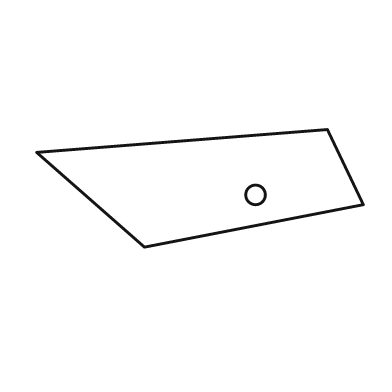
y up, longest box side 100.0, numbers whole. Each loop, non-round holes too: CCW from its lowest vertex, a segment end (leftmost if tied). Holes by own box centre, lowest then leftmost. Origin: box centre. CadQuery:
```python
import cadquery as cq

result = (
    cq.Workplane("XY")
    .moveTo(-17.0, -18.0)
    .lineTo(50.0, -5.0)
    .lineTo(39.0, 18.0)
    .lineTo(-50.0, 11.0)
    .close()
    .moveTo(17.0, -2.0)
    .circle(3.0)
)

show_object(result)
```